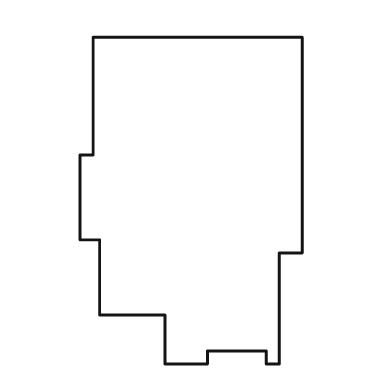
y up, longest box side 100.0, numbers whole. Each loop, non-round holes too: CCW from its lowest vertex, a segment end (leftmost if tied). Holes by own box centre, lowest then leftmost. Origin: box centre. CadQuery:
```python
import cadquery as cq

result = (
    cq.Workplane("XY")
    .moveTo(-8.0, -50.0)
    .lineTo(5.0, -50.0)
    .lineTo(5.0, -46.0)
    .lineTo(23.0, -46.0)
    .lineTo(23.0, -50.0)
    .lineTo(27.0, -50.0)
    .lineTo(27.0, -16.0)
    .lineTo(34.0, -16.0)
    .lineTo(34.0, 50.0)
    .lineTo(-30.0, 50.0)
    .lineTo(-30.0, 14.0)
    .lineTo(-34.0, 14.0)
    .lineTo(-34.0, -12.0)
    .lineTo(-28.0, -12.0)
    .lineTo(-28.0, -35.0)
    .lineTo(-8.0, -35.0)
    .close()
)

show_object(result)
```